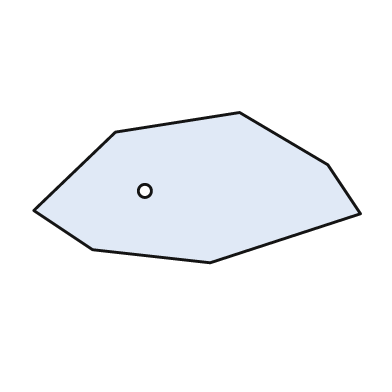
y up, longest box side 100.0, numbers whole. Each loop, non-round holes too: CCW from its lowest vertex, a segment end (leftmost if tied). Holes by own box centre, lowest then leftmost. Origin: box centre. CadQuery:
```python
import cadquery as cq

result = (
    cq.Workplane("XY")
    .moveTo(4.0, -23.0)
    .lineTo(50.0, -8.0)
    .lineTo(40.0, 7.0)
    .lineTo(13.0, 23.0)
    .lineTo(-25.0, 17.0)
    .lineTo(-50.0, -7.0)
    .lineTo(-32.0, -19.0)
    .close()
    .moveTo(-16.0, -1.0)
    .circle(2.0)
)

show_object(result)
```